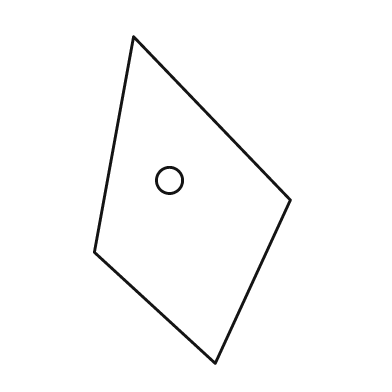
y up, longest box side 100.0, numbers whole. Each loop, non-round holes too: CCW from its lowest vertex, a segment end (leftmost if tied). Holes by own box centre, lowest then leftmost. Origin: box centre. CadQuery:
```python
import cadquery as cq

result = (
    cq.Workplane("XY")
    .moveTo(7.0, -50.0)
    .lineTo(30.0, 0.0)
    .lineTo(-18.0, 50.0)
    .lineTo(-30.0, -16.0)
    .close()
    .moveTo(-7.0, 6.0)
    .circle(4.0)
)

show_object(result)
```